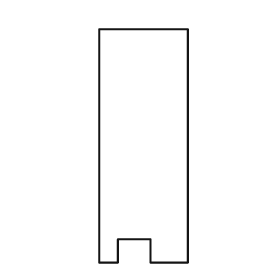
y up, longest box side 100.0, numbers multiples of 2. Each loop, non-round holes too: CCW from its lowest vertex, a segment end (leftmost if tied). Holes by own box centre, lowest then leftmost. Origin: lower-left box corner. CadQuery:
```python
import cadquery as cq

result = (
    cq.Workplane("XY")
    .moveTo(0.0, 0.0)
    .lineTo(8.0, 0.0)
    .lineTo(8.0, 10.0)
    .lineTo(22.0, 10.0)
    .lineTo(22.0, 0.0)
    .lineTo(38.0, 0.0)
    .lineTo(38.0, 100.0)
    .lineTo(0.0, 100.0)
    .close()
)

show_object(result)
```